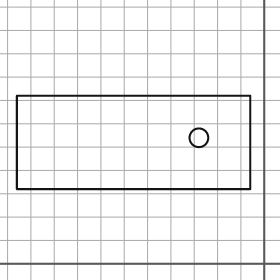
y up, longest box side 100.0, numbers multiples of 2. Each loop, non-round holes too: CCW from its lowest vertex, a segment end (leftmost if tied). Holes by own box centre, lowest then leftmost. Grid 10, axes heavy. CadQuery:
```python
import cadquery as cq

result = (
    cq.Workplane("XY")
    .moveTo(-106.0, 32.0)
    .lineTo(-6.0, 32.0)
    .lineTo(-6.0, 72.0)
    .lineTo(-106.0, 72.0)
    .close()
    .moveTo(-28.0, 54.0)
    .circle(4.0)
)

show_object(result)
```